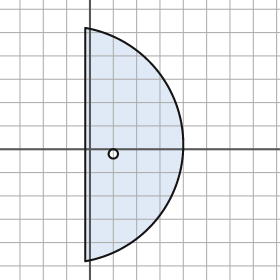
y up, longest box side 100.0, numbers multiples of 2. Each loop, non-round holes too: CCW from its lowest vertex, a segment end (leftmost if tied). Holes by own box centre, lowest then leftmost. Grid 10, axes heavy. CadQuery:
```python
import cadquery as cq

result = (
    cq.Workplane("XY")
    .moveTo(-2.0, -48.0)
    .threePointArc((40.0, 2.0), (-2.0, 52.0))
    .close()
    .moveTo(10.0, -2.0)
    .circle(2.0)
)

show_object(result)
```